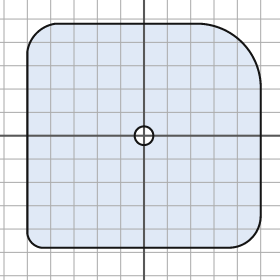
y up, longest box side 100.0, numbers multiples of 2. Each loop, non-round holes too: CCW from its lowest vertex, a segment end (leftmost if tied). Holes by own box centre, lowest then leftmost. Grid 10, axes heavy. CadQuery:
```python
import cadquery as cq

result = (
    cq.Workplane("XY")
    .moveTo(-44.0, -48.0)
    .lineTo(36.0, -48.0)
    .threePointArc((46.0, -44.0), (50.0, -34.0))
    .lineTo(50.0, 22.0)
    .threePointArc((42.0, 40.0), (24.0, 48.0))
    .lineTo(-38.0, 48.0)
    .threePointArc((-46.0, 44.0), (-50.0, 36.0))
    .lineTo(-50.0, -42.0)
    .threePointArc((-48.0, -46.0), (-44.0, -48.0))
    .close()
    .moveTo(0.0, 0.0)
    .circle(4.0)
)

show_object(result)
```